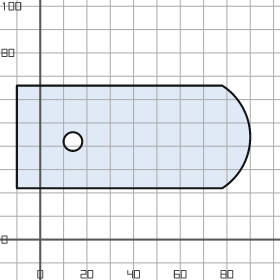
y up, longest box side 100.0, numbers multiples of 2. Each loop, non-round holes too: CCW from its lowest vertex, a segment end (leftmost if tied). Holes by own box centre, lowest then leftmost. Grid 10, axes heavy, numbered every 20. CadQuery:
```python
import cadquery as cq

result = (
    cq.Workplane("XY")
    .moveTo(-10.0, 22.0)
    .lineTo(78.0, 22.0)
    .threePointArc((90.0, 44.0), (78.0, 66.0))
    .lineTo(-10.0, 66.0)
    .close()
    .moveTo(14.0, 42.0)
    .circle(4.0)
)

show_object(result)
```